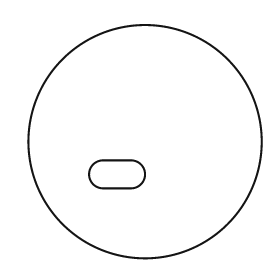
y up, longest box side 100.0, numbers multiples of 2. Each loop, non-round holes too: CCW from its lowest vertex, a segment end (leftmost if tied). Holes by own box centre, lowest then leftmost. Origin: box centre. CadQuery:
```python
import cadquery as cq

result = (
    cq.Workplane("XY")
    .moveTo(0.0, 0.0)
    .circle(50.0)
    .moveTo(-18.0, -20.0)
    .lineTo(-6.0, -20.0)
    .threePointArc((0.0, -14.0), (-6.0, -8.0))
    .lineTo(-18.0, -8.0)
    .threePointArc((-24.0, -14.0), (-18.0, -20.0))
    .close()
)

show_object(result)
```